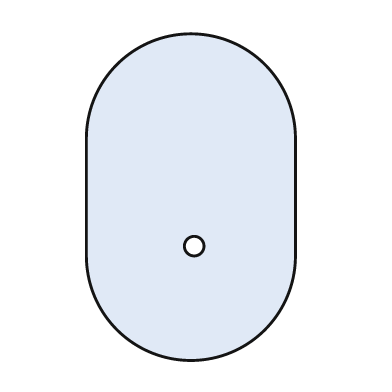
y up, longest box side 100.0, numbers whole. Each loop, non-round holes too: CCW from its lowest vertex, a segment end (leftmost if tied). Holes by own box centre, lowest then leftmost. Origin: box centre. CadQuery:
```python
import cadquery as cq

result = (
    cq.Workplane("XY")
    .moveTo(-32.0, -18.0)
    .threePointArc((0.0, -50.0), (32.0, -18.0))
    .lineTo(32.0, 18.0)
    .threePointArc((0.0, 50.0), (-32.0, 18.0))
    .close()
    .moveTo(1.0, -15.0)
    .circle(3.0)
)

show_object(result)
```